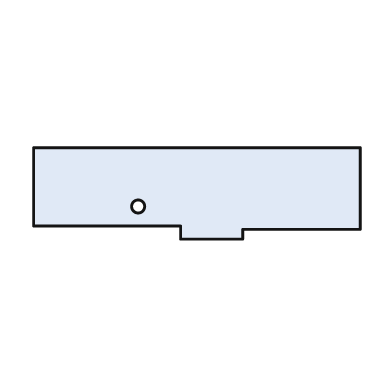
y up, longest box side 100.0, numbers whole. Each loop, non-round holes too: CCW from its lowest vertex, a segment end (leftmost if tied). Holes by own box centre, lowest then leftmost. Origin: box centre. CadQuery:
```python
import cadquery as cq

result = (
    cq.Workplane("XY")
    .moveTo(-5.0, -14.0)
    .lineTo(14.0, -14.0)
    .lineTo(14.0, -11.0)
    .lineTo(50.0, -11.0)
    .lineTo(50.0, 14.0)
    .lineTo(-50.0, 14.0)
    .lineTo(-50.0, -10.0)
    .lineTo(-5.0, -10.0)
    .close()
    .moveTo(-18.0, -4.0)
    .circle(2.0)
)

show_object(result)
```